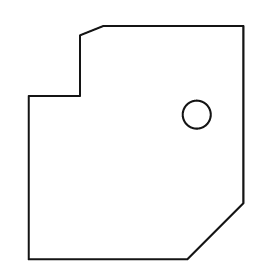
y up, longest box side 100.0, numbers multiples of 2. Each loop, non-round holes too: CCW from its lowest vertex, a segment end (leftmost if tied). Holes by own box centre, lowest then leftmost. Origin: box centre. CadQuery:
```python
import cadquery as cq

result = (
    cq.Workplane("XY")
    .moveTo(-46.0, -50.0)
    .lineTo(22.0, -50.0)
    .lineTo(46.0, -26.0)
    .lineTo(46.0, 50.0)
    .lineTo(-14.0, 50.0)
    .lineTo(-24.0, 46.0)
    .lineTo(-24.0, 20.0)
    .lineTo(-46.0, 20.0)
    .close()
    .moveTo(26.0, 12.0)
    .circle(6.0)
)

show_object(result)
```